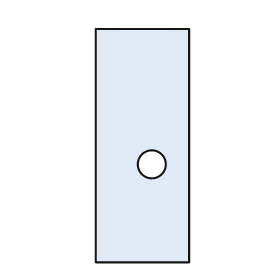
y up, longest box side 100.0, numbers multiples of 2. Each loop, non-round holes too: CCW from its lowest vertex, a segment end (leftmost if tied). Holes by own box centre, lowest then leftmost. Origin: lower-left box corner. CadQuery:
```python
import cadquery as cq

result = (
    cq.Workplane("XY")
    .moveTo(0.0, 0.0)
    .lineTo(40.0, 0.0)
    .lineTo(40.0, 100.0)
    .lineTo(0.0, 100.0)
    .close()
    .moveTo(24.0, 42.0)
    .circle(6.0)
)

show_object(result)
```